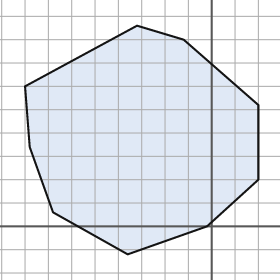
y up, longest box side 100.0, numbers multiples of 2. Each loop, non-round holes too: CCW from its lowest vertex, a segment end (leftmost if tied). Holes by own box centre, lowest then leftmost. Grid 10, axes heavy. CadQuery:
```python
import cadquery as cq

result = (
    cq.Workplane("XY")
    .moveTo(-36.0, -12.0)
    .lineTo(-2.0, 0.0)
    .lineTo(20.0, 20.0)
    .lineTo(20.0, 52.0)
    .lineTo(-12.0, 80.0)
    .lineTo(-32.0, 86.0)
    .lineTo(-80.0, 60.0)
    .lineTo(-78.0, 34.0)
    .lineTo(-68.0, 6.0)
    .close()
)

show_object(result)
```